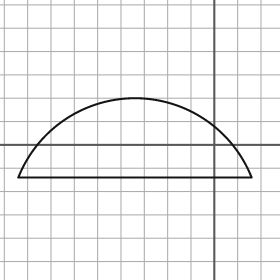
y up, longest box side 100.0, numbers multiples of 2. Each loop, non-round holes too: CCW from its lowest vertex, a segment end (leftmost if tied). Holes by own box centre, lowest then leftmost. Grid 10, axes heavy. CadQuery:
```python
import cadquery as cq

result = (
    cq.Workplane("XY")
    .moveTo(-84.0, -14.0)
    .lineTo(16.0, -14.0)
    .threePointArc((-34.0, 20.0), (-84.0, -14.0))
    .close()
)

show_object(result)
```